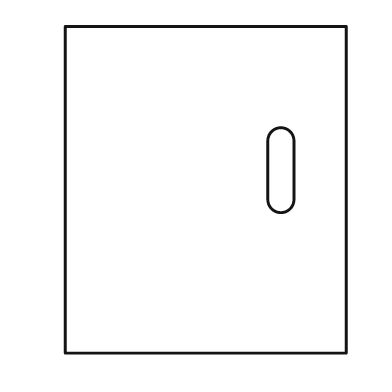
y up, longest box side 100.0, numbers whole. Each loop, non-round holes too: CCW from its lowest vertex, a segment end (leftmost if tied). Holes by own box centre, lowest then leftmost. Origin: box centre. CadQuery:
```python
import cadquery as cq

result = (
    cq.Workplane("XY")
    .moveTo(-43.0, -50.0)
    .lineTo(43.0, -50.0)
    .lineTo(43.0, 50.0)
    .lineTo(-43.0, 50.0)
    .close()
    .moveTo(19.0, -3.0)
    .threePointArc((23.0, -7.0), (27.0, -3.0))
    .lineTo(27.0, 15.0)
    .threePointArc((23.0, 19.0), (19.0, 15.0))
    .close()
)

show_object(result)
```